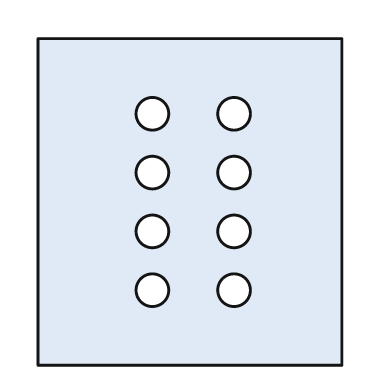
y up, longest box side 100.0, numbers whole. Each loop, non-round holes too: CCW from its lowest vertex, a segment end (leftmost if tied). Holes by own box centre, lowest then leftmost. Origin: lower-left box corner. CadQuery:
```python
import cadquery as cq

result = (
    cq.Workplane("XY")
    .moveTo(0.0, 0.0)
    .lineTo(93.0, 0.0)
    .lineTo(93.0, 100.0)
    .lineTo(0.0, 100.0)
    .close()
    .moveTo(35.0, 23.0)
    .circle(5.0)
    .moveTo(60.0, 23.0)
    .circle(5.0)
    .moveTo(35.0, 41.0)
    .circle(5.0)
    .moveTo(60.0, 41.0)
    .circle(5.0)
    .moveTo(35.0, 59.0)
    .circle(5.0)
    .moveTo(60.0, 59.0)
    .circle(5.0)
    .moveTo(35.0, 77.0)
    .circle(5.0)
    .moveTo(60.0, 77.0)
    .circle(5.0)
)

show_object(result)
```